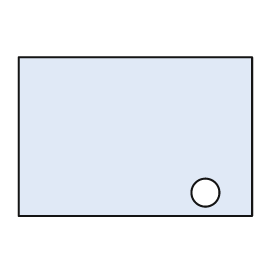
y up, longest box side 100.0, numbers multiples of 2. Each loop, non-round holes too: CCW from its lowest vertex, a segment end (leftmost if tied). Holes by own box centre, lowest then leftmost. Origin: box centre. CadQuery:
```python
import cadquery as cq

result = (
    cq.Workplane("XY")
    .moveTo(-50.0, -34.0)
    .lineTo(50.0, -34.0)
    .lineTo(50.0, 34.0)
    .lineTo(-50.0, 34.0)
    .close()
    .moveTo(30.0, -24.0)
    .circle(6.0)
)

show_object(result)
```